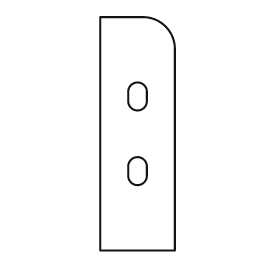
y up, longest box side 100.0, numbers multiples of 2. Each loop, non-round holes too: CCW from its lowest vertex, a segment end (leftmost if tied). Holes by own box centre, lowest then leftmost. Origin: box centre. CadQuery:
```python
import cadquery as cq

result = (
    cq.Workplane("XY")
    .moveTo(-16.0, -50.0)
    .lineTo(16.0, -50.0)
    .lineTo(16.0, 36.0)
    .threePointArc((12.0, 46.0), (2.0, 50.0))
    .lineTo(-16.0, 50.0)
    .close()
    .moveTo(-4.0, -18.0)
    .threePointArc((0.0, -22.0), (4.0, -18.0))
    .lineTo(4.0, -14.0)
    .threePointArc((0.0, -10.0), (-4.0, -14.0))
    .close()
    .moveTo(-4.0, 14.0)
    .threePointArc((0.0, 10.0), (4.0, 14.0))
    .lineTo(4.0, 18.0)
    .threePointArc((0.0, 22.0), (-4.0, 18.0))
    .close()
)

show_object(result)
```